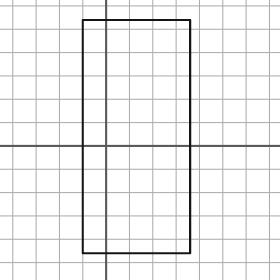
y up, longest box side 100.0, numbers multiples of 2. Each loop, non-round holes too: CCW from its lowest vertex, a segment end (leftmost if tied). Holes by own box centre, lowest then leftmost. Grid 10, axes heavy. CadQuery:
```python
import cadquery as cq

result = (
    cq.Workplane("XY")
    .moveTo(-10.0, -46.0)
    .lineTo(36.0, -46.0)
    .lineTo(36.0, 54.0)
    .lineTo(-10.0, 54.0)
    .close()
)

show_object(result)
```